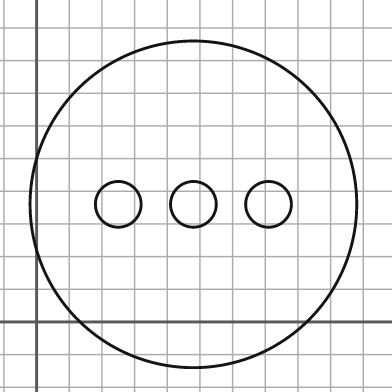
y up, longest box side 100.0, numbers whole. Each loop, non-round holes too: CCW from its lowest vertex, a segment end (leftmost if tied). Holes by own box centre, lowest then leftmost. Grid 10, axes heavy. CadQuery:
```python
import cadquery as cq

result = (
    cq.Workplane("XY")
    .moveTo(48.0, 36.0)
    .circle(50.0)
    .moveTo(25.0, 36.0)
    .circle(7.0)
    .moveTo(48.0, 36.0)
    .circle(7.0)
    .moveTo(71.0, 36.0)
    .circle(7.0)
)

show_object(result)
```